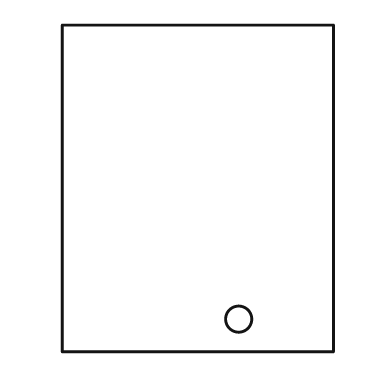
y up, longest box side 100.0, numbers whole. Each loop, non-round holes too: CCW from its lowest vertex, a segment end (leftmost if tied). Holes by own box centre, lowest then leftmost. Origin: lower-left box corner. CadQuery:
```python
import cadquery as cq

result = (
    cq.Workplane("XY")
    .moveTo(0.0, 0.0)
    .lineTo(83.0, 0.0)
    .lineTo(83.0, 100.0)
    .lineTo(0.0, 100.0)
    .close()
    .moveTo(54.0, 10.0)
    .circle(4.0)
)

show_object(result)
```